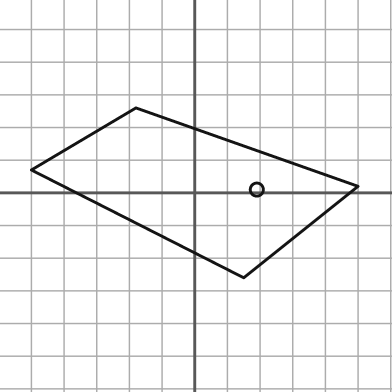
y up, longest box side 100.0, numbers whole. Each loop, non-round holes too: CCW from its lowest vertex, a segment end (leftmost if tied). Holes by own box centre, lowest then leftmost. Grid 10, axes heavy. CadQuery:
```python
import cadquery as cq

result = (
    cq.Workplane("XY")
    .moveTo(15.0, -26.0)
    .lineTo(50.0, 2.0)
    .lineTo(-18.0, 26.0)
    .lineTo(-50.0, 7.0)
    .close()
    .moveTo(19.0, 1.0)
    .circle(2.0)
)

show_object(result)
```